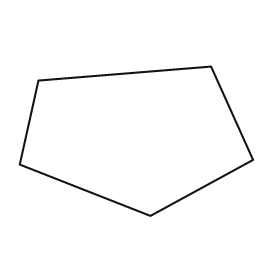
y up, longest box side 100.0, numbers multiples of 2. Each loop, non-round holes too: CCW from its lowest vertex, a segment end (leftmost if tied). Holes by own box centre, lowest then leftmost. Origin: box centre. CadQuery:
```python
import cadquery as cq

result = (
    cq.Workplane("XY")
    .moveTo(6.0, -32.0)
    .lineTo(50.0, -8.0)
    .lineTo(32.0, 32.0)
    .lineTo(-42.0, 26.0)
    .lineTo(-50.0, -10.0)
    .close()
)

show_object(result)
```